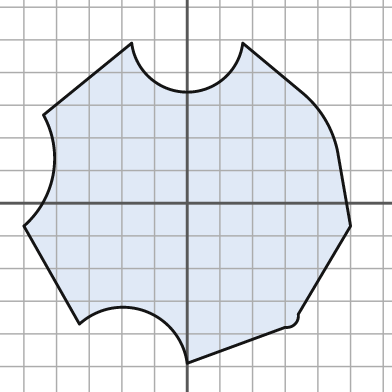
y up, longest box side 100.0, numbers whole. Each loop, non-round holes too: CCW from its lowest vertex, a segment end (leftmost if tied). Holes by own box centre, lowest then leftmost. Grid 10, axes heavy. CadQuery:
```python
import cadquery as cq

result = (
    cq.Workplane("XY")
    .moveTo(0.0, -49.0)
    .lineTo(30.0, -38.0)
    .threePointArc((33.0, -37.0), (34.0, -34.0))
    .lineTo(50.0, -7.0)
    .lineTo(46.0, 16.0)
    .threePointArc((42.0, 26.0), (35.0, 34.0))
    .lineTo(17.0, 49.0)
    .threePointArc((0.0, 34.0), (-17.0, 49.0))
    .lineTo(-44.0, 27.0)
    .threePointArc((-41.0, 9.0), (-50.0, -7.0))
    .lineTo(-33.0, -37.0)
    .threePointArc((-13.0, -33.0), (0.0, -49.0))
    .close()
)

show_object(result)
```